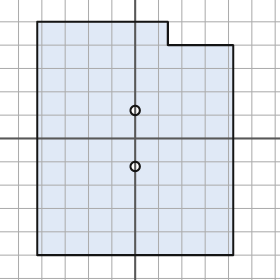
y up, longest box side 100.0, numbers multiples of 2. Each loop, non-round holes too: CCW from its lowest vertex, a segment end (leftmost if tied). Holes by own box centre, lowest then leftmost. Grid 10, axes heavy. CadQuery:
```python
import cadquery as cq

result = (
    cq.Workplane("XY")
    .moveTo(-42.0, -50.0)
    .lineTo(42.0, -50.0)
    .lineTo(42.0, 40.0)
    .lineTo(14.0, 40.0)
    .lineTo(14.0, 50.0)
    .lineTo(-42.0, 50.0)
    .close()
    .moveTo(0.0, -12.0)
    .circle(2.0)
    .moveTo(0.0, 12.0)
    .circle(2.0)
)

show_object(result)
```